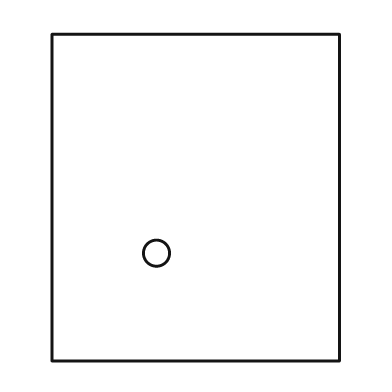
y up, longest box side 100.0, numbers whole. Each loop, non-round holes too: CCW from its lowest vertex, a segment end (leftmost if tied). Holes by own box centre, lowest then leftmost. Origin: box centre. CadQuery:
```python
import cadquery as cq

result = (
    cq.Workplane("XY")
    .moveTo(-44.0, -50.0)
    .lineTo(44.0, -50.0)
    .lineTo(44.0, 50.0)
    .lineTo(-44.0, 50.0)
    .close()
    .moveTo(-12.0, -17.0)
    .circle(4.0)
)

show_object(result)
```